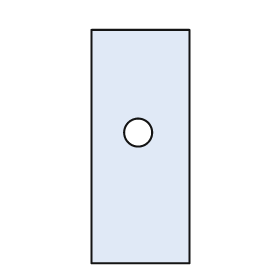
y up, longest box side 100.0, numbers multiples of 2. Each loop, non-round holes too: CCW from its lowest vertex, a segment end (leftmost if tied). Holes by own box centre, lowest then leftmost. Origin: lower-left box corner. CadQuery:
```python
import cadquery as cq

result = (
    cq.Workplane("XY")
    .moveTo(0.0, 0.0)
    .lineTo(42.0, 0.0)
    .lineTo(42.0, 100.0)
    .lineTo(0.0, 100.0)
    .close()
    .moveTo(20.0, 56.0)
    .circle(6.0)
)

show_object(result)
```